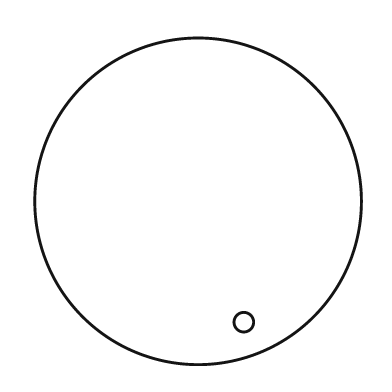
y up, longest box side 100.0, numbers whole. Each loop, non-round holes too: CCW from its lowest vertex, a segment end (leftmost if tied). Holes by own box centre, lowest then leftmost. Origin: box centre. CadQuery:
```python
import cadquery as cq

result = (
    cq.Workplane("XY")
    .moveTo(0.0, 0.0)
    .circle(50.0)
    .moveTo(14.0, -37.0)
    .circle(3.0)
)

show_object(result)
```